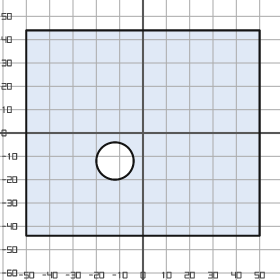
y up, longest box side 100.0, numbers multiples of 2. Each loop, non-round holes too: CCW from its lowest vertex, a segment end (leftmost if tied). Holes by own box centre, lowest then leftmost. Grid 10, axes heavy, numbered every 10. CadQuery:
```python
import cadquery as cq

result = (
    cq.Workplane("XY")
    .moveTo(-50.0, -44.0)
    .lineTo(50.0, -44.0)
    .lineTo(50.0, 44.0)
    .lineTo(-50.0, 44.0)
    .close()
    .moveTo(-12.0, -12.0)
    .circle(8.0)
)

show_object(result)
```